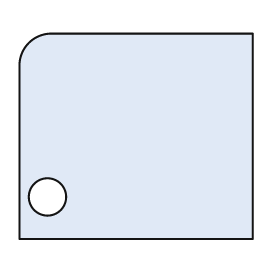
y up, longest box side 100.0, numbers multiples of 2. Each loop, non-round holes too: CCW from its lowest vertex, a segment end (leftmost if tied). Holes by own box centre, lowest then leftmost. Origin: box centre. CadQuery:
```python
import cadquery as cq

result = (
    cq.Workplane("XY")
    .moveTo(-50.0, -44.0)
    .lineTo(50.0, -44.0)
    .lineTo(50.0, 44.0)
    .lineTo(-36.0, 44.0)
    .threePointArc((-46.0, 40.0), (-50.0, 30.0))
    .close()
    .moveTo(-38.0, -26.0)
    .circle(8.0)
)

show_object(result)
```